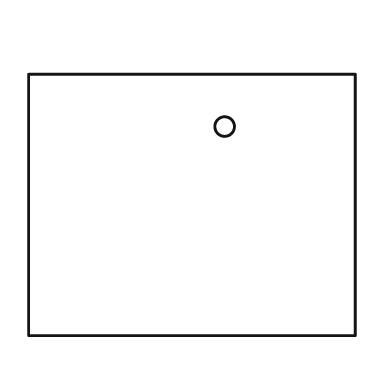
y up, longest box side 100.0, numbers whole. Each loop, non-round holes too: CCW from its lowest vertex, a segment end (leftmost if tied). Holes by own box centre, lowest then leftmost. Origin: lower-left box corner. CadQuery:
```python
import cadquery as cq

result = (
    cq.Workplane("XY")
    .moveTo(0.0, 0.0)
    .lineTo(100.0, 0.0)
    .lineTo(100.0, 80.0)
    .lineTo(0.0, 80.0)
    .close()
    .moveTo(60.0, 64.0)
    .circle(3.0)
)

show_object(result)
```